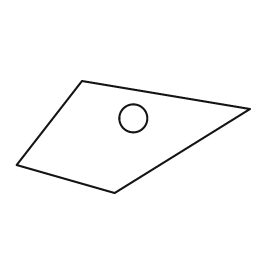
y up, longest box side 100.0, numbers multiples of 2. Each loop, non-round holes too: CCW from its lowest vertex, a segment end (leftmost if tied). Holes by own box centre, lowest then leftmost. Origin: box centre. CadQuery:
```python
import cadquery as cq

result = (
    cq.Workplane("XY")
    .moveTo(-8.0, -24.0)
    .lineTo(50.0, 12.0)
    .lineTo(-22.0, 24.0)
    .lineTo(-50.0, -12.0)
    .close()
    .moveTo(0.0, 8.0)
    .circle(6.0)
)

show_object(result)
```